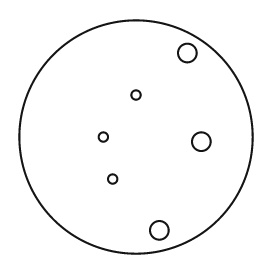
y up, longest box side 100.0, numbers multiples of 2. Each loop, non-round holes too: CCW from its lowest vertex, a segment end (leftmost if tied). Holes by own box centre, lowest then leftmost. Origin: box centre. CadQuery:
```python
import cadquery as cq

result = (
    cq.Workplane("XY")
    .moveTo(0.0, 0.0)
    .circle(50.0)
    .moveTo(10.0, -40.0)
    .circle(4.0)
    .moveTo(-10.0, -18.0)
    .circle(2.0)
    .moveTo(28.0, -2.0)
    .circle(4.0)
    .moveTo(-14.0, 0.0)
    .circle(2.0)
    .moveTo(0.0, 18.0)
    .circle(2.0)
    .moveTo(22.0, 36.0)
    .circle(4.0)
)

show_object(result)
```